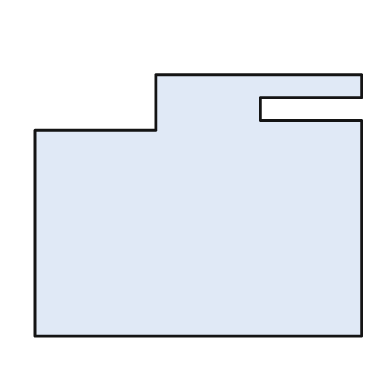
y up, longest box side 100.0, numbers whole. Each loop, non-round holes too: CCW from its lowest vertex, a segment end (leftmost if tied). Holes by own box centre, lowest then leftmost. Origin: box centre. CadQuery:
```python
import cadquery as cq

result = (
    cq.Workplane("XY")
    .moveTo(-50.0, -40.0)
    .lineTo(50.0, -40.0)
    .lineTo(50.0, 26.0)
    .lineTo(19.0, 26.0)
    .lineTo(19.0, 33.0)
    .lineTo(50.0, 33.0)
    .lineTo(50.0, 40.0)
    .lineTo(-13.0, 40.0)
    .lineTo(-13.0, 23.0)
    .lineTo(-50.0, 23.0)
    .close()
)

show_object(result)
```